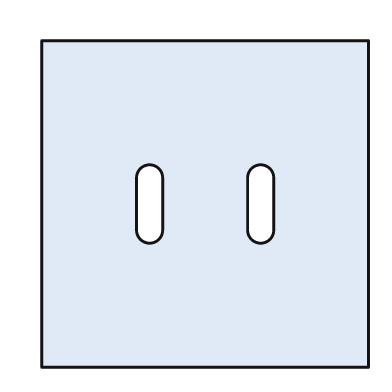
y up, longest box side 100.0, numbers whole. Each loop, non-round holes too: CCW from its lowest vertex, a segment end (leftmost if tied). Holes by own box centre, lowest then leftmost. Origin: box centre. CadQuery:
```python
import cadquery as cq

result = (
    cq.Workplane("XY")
    .moveTo(-50.0, -50.0)
    .lineTo(50.0, -50.0)
    .lineTo(50.0, 50.0)
    .lineTo(-50.0, 50.0)
    .close()
    .moveTo(-21.0, -8.0)
    .threePointArc((-17.0, -12.0), (-13.0, -8.0))
    .lineTo(-13.0, 8.0)
    .threePointArc((-17.0, 12.0), (-21.0, 8.0))
    .close()
    .moveTo(13.0, -8.0)
    .threePointArc((17.0, -12.0), (21.0, -8.0))
    .lineTo(21.0, 8.0)
    .threePointArc((17.0, 12.0), (13.0, 8.0))
    .close()
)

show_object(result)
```